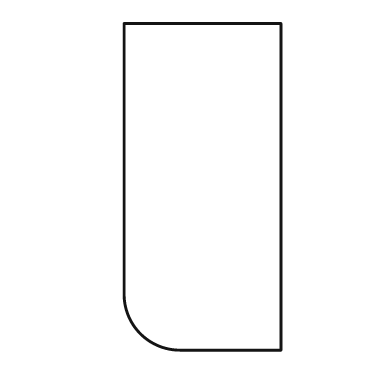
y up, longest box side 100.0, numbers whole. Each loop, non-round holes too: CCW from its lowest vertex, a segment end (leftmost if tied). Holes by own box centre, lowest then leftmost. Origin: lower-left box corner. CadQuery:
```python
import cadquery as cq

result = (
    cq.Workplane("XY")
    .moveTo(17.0, 0.0)
    .lineTo(48.0, 0.0)
    .lineTo(48.0, 100.0)
    .lineTo(0.0, 100.0)
    .lineTo(0.0, 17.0)
    .threePointArc((5.0, 5.0), (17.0, 0.0))
    .close()
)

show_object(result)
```